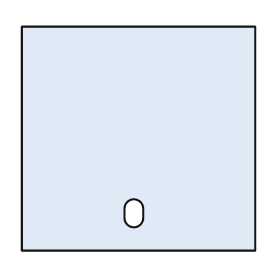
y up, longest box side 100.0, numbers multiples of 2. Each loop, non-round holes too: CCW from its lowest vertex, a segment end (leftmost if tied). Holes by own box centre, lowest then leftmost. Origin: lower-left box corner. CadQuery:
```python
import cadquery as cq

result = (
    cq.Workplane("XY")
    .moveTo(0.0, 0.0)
    .lineTo(100.0, 0.0)
    .lineTo(100.0, 96.0)
    .lineTo(0.0, 96.0)
    .close()
    .moveTo(44.0, 14.0)
    .threePointArc((48.0, 10.0), (52.0, 14.0))
    .lineTo(52.0, 18.0)
    .threePointArc((48.0, 22.0), (44.0, 18.0))
    .close()
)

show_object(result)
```